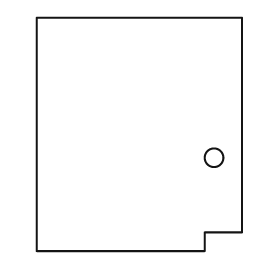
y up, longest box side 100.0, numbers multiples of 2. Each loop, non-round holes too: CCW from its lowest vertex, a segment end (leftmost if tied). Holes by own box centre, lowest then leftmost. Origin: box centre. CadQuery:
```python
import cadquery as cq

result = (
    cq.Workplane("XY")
    .moveTo(-44.0, -50.0)
    .lineTo(28.0, -50.0)
    .lineTo(28.0, -42.0)
    .lineTo(44.0, -42.0)
    .lineTo(44.0, 50.0)
    .lineTo(-44.0, 50.0)
    .close()
    .moveTo(32.0, -10.0)
    .circle(4.0)
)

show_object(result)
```